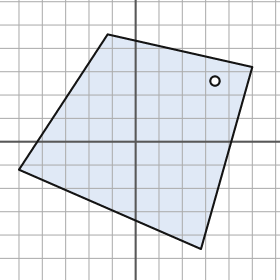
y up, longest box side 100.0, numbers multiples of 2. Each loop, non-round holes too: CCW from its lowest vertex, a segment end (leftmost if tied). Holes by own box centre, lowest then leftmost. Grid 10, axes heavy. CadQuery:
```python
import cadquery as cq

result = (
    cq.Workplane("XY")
    .moveTo(28.0, -46.0)
    .lineTo(50.0, 32.0)
    .lineTo(-12.0, 46.0)
    .lineTo(-50.0, -12.0)
    .close()
    .moveTo(34.0, 26.0)
    .circle(2.0)
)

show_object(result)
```